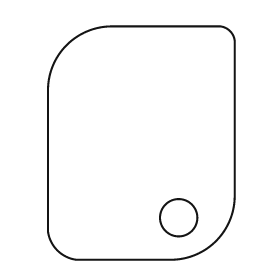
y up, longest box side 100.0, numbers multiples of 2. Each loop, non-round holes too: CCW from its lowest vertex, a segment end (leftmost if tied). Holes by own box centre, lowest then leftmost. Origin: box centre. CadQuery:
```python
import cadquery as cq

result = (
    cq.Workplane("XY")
    .moveTo(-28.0, -50.0)
    .lineTo(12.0, -50.0)
    .threePointArc((32.0, -42.0), (40.0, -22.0))
    .lineTo(40.0, 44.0)
    .threePointArc((38.0, 48.0), (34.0, 50.0))
    .lineTo(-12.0, 50.0)
    .threePointArc((-32.0, 42.0), (-40.0, 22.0))
    .lineTo(-40.0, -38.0)
    .threePointArc((-36.0, -46.0), (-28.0, -50.0))
    .close()
    .moveTo(16.0, -32.0)
    .circle(8.0)
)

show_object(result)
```